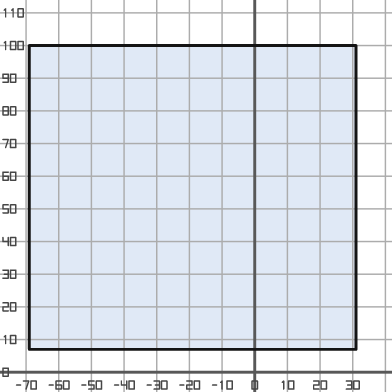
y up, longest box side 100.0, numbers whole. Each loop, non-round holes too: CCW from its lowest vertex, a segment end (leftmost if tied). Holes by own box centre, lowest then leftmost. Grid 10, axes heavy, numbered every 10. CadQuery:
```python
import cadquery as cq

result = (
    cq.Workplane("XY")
    .moveTo(-69.0, 7.0)
    .lineTo(31.0, 7.0)
    .lineTo(31.0, 100.0)
    .lineTo(-69.0, 100.0)
    .close()
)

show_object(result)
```